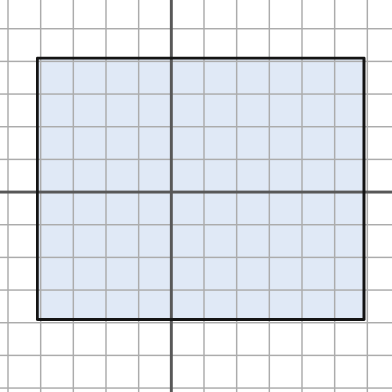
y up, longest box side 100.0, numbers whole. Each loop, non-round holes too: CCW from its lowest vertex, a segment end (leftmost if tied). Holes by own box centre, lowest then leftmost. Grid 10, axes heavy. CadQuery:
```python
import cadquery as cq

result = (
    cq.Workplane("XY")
    .moveTo(-41.0, -39.0)
    .lineTo(59.0, -39.0)
    .lineTo(59.0, 41.0)
    .lineTo(-41.0, 41.0)
    .close()
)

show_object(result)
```